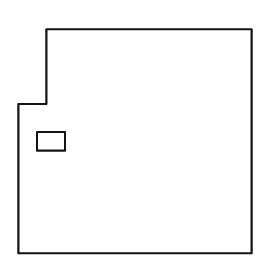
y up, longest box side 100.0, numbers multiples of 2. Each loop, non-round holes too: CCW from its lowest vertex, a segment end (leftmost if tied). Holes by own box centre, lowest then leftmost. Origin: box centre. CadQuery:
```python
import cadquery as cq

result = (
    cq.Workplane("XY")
    .moveTo(-50.0, -48.0)
    .lineTo(50.0, -48.0)
    .lineTo(50.0, 48.0)
    .lineTo(-38.0, 48.0)
    .lineTo(-38.0, 16.0)
    .lineTo(-50.0, 16.0)
    .close()
    .moveTo(-42.0, -4.0)
    .lineTo(-30.0, -4.0)
    .lineTo(-30.0, 4.0)
    .lineTo(-42.0, 4.0)
    .close()
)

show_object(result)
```